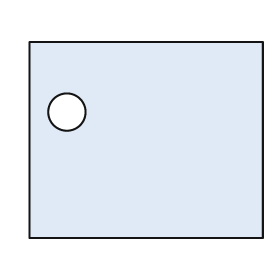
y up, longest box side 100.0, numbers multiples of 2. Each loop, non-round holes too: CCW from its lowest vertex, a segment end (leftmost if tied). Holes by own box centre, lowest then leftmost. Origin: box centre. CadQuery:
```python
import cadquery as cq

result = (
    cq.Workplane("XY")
    .moveTo(-50.0, -42.0)
    .lineTo(50.0, -42.0)
    .lineTo(50.0, 42.0)
    .lineTo(-50.0, 42.0)
    .close()
    .moveTo(-34.0, 12.0)
    .circle(8.0)
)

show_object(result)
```